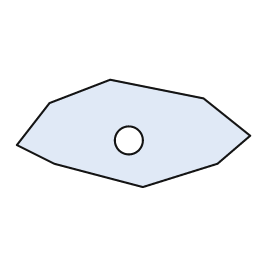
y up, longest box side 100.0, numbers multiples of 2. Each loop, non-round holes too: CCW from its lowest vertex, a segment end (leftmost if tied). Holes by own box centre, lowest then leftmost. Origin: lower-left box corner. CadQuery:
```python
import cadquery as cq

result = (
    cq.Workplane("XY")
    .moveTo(54.0, 0.0)
    .lineTo(86.0, 10.0)
    .lineTo(100.0, 22.0)
    .lineTo(80.0, 38.0)
    .lineTo(40.0, 46.0)
    .lineTo(14.0, 36.0)
    .lineTo(0.0, 18.0)
    .lineTo(16.0, 10.0)
    .close()
    .moveTo(48.0, 20.0)
    .circle(6.0)
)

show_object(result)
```